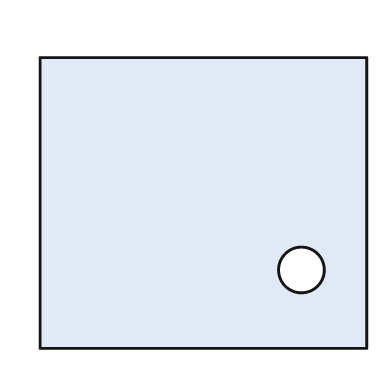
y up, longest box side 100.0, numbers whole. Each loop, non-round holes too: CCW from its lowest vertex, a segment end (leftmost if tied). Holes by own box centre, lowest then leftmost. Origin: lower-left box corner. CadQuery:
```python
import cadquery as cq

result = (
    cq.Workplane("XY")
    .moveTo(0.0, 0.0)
    .lineTo(100.0, 0.0)
    .lineTo(100.0, 89.0)
    .lineTo(0.0, 89.0)
    .close()
    .moveTo(80.0, 24.0)
    .circle(7.0)
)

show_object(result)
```